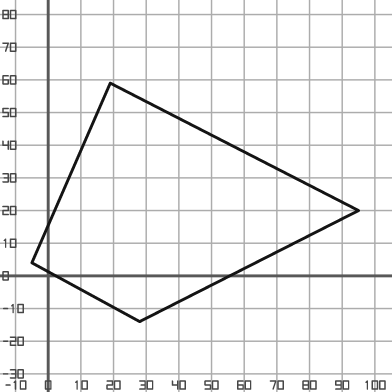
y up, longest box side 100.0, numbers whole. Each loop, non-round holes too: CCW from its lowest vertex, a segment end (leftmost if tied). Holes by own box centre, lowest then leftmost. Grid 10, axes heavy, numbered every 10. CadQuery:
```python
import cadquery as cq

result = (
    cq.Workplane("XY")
    .moveTo(28.0, -14.0)
    .lineTo(95.0, 20.0)
    .lineTo(19.0, 59.0)
    .lineTo(-5.0, 4.0)
    .close()
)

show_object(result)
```